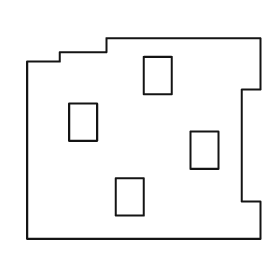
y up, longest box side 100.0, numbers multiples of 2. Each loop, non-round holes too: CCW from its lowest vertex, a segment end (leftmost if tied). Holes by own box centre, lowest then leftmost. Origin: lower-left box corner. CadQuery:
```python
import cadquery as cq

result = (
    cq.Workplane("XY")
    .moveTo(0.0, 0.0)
    .lineTo(100.0, 0.0)
    .lineTo(100.0, 16.0)
    .lineTo(92.0, 16.0)
    .lineTo(92.0, 64.0)
    .lineTo(100.0, 64.0)
    .lineTo(100.0, 86.0)
    .lineTo(34.0, 86.0)
    .lineTo(34.0, 80.0)
    .lineTo(14.0, 80.0)
    .lineTo(14.0, 76.0)
    .lineTo(0.0, 76.0)
    .close()
    .moveTo(38.0, 10.0)
    .lineTo(50.0, 10.0)
    .lineTo(50.0, 26.0)
    .lineTo(38.0, 26.0)
    .close()
    .moveTo(70.0, 30.0)
    .lineTo(82.0, 30.0)
    .lineTo(82.0, 46.0)
    .lineTo(70.0, 46.0)
    .close()
    .moveTo(18.0, 42.0)
    .lineTo(30.0, 42.0)
    .lineTo(30.0, 58.0)
    .lineTo(18.0, 58.0)
    .close()
    .moveTo(50.0, 62.0)
    .lineTo(62.0, 62.0)
    .lineTo(62.0, 78.0)
    .lineTo(50.0, 78.0)
    .close()
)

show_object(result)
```